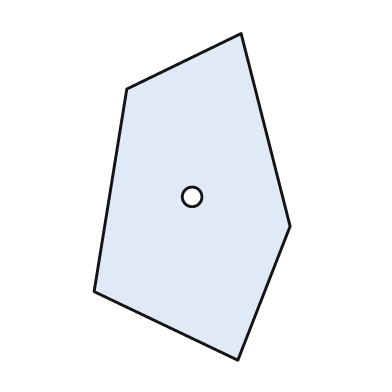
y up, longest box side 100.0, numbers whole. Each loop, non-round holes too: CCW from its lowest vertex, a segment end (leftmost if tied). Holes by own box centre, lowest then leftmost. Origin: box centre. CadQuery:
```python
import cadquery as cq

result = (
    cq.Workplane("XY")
    .moveTo(14.0, -50.0)
    .lineTo(30.0, -9.0)
    .lineTo(15.0, 50.0)
    .lineTo(-20.0, 33.0)
    .lineTo(-30.0, -29.0)
    .close()
    .moveTo(0.0, 0.0)
    .circle(3.0)
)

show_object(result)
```